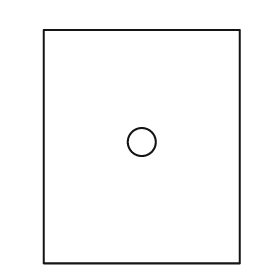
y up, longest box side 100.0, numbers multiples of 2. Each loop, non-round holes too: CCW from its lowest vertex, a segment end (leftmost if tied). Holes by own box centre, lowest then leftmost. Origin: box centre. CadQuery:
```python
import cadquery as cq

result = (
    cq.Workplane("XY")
    .moveTo(-42.0, -50.0)
    .lineTo(42.0, -50.0)
    .lineTo(42.0, 50.0)
    .lineTo(-42.0, 50.0)
    .close()
    .moveTo(0.0, 2.0)
    .circle(6.0)
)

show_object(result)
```